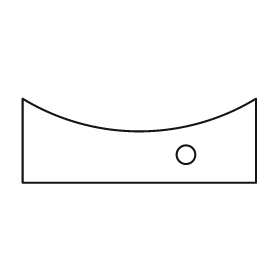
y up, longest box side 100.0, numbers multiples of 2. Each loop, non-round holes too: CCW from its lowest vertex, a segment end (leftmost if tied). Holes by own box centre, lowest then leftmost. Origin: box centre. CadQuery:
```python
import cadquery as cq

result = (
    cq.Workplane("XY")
    .moveTo(-50.0, -18.0)
    .lineTo(50.0, -18.0)
    .lineTo(50.0, 18.0)
    .threePointArc((0.0, 4.0), (-50.0, 18.0))
    .close()
    .moveTo(20.0, -6.0)
    .circle(4.0)
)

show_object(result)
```